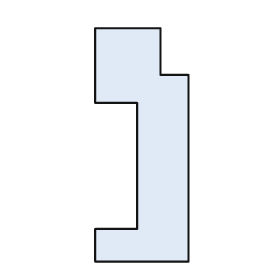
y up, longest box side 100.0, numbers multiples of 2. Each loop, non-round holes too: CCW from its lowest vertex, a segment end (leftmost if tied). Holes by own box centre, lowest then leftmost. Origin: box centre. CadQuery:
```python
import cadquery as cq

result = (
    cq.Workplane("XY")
    .moveTo(-20.0, -50.0)
    .lineTo(20.0, -50.0)
    .lineTo(20.0, 30.0)
    .lineTo(8.0, 30.0)
    .lineTo(8.0, 50.0)
    .lineTo(-20.0, 50.0)
    .lineTo(-20.0, 18.0)
    .lineTo(-2.0, 18.0)
    .lineTo(-2.0, -36.0)
    .lineTo(-20.0, -36.0)
    .close()
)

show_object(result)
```